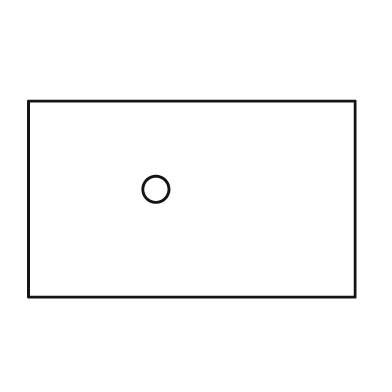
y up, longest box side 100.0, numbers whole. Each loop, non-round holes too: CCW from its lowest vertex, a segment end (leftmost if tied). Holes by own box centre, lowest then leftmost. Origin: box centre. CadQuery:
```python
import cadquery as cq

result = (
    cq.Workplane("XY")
    .moveTo(-50.0, -30.0)
    .lineTo(50.0, -30.0)
    .lineTo(50.0, 30.0)
    .lineTo(-50.0, 30.0)
    .close()
    .moveTo(-11.0, 3.0)
    .circle(4.0)
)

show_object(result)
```